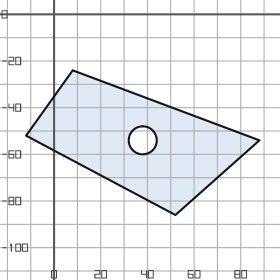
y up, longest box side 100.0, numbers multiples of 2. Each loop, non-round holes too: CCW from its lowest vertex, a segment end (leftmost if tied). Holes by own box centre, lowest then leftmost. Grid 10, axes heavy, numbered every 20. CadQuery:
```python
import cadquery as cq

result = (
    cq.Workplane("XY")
    .moveTo(52.0, -86.0)
    .lineTo(88.0, -54.0)
    .lineTo(8.0, -24.0)
    .lineTo(-12.0, -52.0)
    .close()
    .moveTo(38.0, -54.0)
    .circle(6.0)
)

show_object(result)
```